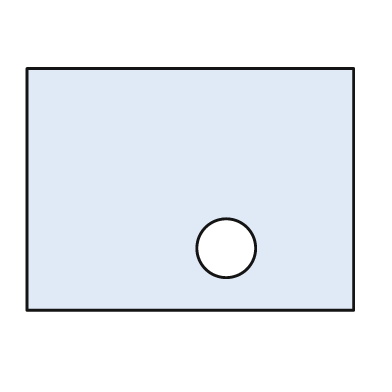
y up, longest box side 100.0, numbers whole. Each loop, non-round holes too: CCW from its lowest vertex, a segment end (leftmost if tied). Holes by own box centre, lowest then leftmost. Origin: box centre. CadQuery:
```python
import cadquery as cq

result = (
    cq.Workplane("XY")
    .moveTo(-50.0, -37.0)
    .lineTo(50.0, -37.0)
    .lineTo(50.0, 37.0)
    .lineTo(-50.0, 37.0)
    .close()
    .moveTo(11.0, -18.0)
    .circle(9.0)
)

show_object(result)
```